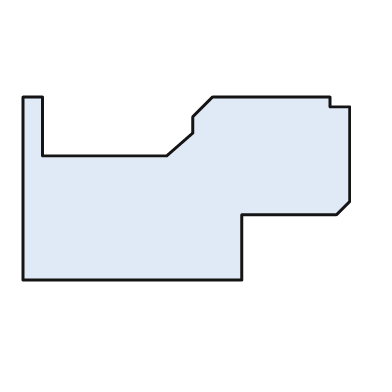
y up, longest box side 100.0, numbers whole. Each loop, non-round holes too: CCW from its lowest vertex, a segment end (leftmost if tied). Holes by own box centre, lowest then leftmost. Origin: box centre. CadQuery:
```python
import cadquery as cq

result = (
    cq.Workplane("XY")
    .moveTo(-50.0, -28.0)
    .lineTo(17.0, -28.0)
    .lineTo(17.0, -8.0)
    .lineTo(46.0, -8.0)
    .lineTo(50.0, -4.0)
    .lineTo(50.0, 25.0)
    .lineTo(44.0, 25.0)
    .lineTo(44.0, 28.0)
    .lineTo(8.0, 28.0)
    .lineTo(2.0, 22.0)
    .lineTo(2.0, 17.0)
    .lineTo(-6.0, 10.0)
    .lineTo(-44.0, 10.0)
    .lineTo(-44.0, 28.0)
    .lineTo(-50.0, 28.0)
    .close()
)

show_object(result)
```